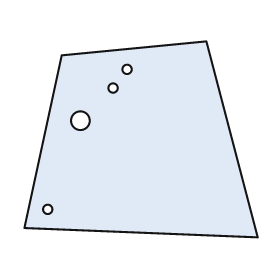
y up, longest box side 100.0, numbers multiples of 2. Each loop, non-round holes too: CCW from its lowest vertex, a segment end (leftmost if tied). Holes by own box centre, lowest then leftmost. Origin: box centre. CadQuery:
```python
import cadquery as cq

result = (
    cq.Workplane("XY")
    .moveTo(50.0, -42.0)
    .lineTo(28.0, 42.0)
    .lineTo(-34.0, 36.0)
    .lineTo(-50.0, -38.0)
    .close()
    .moveTo(-40.0, -30.0)
    .circle(2.0)
    .moveTo(-26.0, 8.0)
    .circle(4.0)
    .moveTo(-12.0, 22.0)
    .circle(2.0)
    .moveTo(-6.0, 30.0)
    .circle(2.0)
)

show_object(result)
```